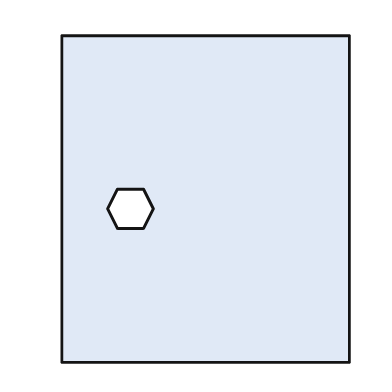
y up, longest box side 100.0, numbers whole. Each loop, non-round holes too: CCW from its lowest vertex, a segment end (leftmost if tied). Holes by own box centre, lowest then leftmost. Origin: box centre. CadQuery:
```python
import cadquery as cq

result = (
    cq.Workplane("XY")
    .moveTo(-44.0, -50.0)
    .lineTo(44.0, -50.0)
    .lineTo(44.0, 50.0)
    .lineTo(-44.0, 50.0)
    .close()
    .moveTo(-27.0, -9.0)
    .lineTo(-19.0, -9.0)
    .lineTo(-16.0, -3.0)
    .lineTo(-19.0, 3.0)
    .lineTo(-27.0, 3.0)
    .lineTo(-30.0, -3.0)
    .close()
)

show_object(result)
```